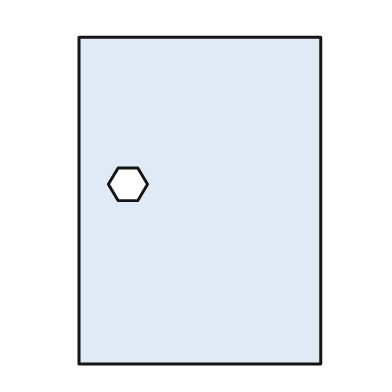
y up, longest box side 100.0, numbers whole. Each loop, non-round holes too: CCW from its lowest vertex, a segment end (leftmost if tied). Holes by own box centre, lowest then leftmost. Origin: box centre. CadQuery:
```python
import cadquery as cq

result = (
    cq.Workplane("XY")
    .moveTo(-37.0, -50.0)
    .lineTo(37.0, -50.0)
    .lineTo(37.0, 50.0)
    .lineTo(-37.0, 50.0)
    .close()
    .moveTo(-25.0, 0.0)
    .lineTo(-19.0, 0.0)
    .lineTo(-16.0, 5.0)
    .lineTo(-19.0, 10.0)
    .lineTo(-25.0, 10.0)
    .lineTo(-28.0, 5.0)
    .close()
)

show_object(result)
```